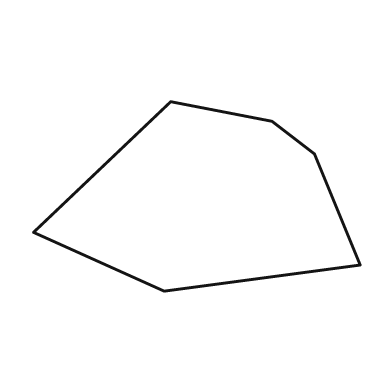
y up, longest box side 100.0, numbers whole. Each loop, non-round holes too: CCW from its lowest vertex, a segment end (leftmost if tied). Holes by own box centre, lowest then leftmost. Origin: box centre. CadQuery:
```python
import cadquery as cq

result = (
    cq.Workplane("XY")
    .moveTo(-10.0, -29.0)
    .lineTo(50.0, -21.0)
    .lineTo(36.0, 13.0)
    .lineTo(23.0, 23.0)
    .lineTo(-8.0, 29.0)
    .lineTo(-50.0, -11.0)
    .close()
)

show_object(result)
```